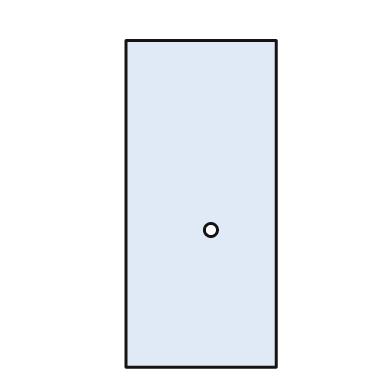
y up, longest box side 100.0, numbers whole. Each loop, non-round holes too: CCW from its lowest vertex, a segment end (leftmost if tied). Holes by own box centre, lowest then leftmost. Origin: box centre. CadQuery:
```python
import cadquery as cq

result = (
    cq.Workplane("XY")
    .moveTo(-23.0, -50.0)
    .lineTo(23.0, -50.0)
    .lineTo(23.0, 50.0)
    .lineTo(-23.0, 50.0)
    .close()
    .moveTo(3.0, -8.0)
    .circle(2.0)
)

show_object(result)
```